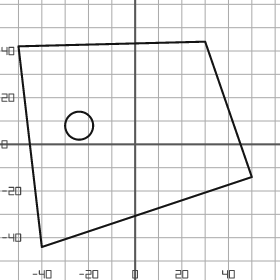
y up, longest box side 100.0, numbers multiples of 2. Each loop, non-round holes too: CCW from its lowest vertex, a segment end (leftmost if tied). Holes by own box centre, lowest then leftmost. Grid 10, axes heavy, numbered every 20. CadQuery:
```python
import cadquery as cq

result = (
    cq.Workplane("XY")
    .moveTo(-40.0, -44.0)
    .lineTo(50.0, -14.0)
    .lineTo(30.0, 44.0)
    .lineTo(-50.0, 42.0)
    .close()
    .moveTo(-24.0, 8.0)
    .circle(6.0)
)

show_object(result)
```